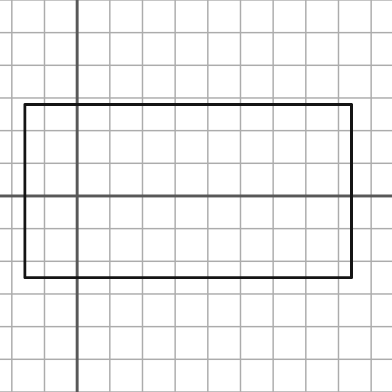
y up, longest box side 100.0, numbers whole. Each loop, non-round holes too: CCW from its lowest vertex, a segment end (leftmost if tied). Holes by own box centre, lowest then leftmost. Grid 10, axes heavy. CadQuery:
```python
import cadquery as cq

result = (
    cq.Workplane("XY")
    .moveTo(-16.0, -25.0)
    .lineTo(84.0, -25.0)
    .lineTo(84.0, 28.0)
    .lineTo(-16.0, 28.0)
    .close()
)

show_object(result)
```